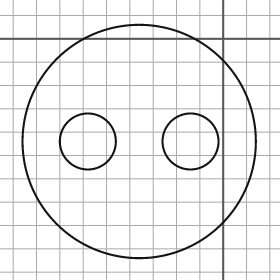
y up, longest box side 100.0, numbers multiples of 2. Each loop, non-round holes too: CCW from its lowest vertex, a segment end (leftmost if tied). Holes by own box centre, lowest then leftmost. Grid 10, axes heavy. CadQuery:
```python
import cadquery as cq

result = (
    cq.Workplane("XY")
    .moveTo(-36.0, -44.0)
    .circle(50.0)
    .moveTo(-58.0, -44.0)
    .circle(12.0)
    .moveTo(-14.0, -44.0)
    .circle(12.0)
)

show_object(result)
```